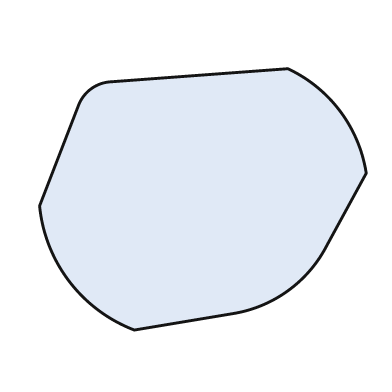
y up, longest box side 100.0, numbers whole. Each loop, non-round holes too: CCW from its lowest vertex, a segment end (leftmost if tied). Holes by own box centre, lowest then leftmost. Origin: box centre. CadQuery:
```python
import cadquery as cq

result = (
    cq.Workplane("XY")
    .moveTo(-21.0, -40.0)
    .lineTo(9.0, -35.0)
    .threePointArc((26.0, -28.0), (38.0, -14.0))
    .lineTo(50.0, 8.0)
    .threePointArc((42.0, 27.0), (26.0, 40.0))
    .lineTo(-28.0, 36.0)
    .threePointArc((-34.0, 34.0), (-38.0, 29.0))
    .lineTo(-50.0, -2.0)
    .threePointArc((-41.0, -25.0), (-21.0, -40.0))
    .close()
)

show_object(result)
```